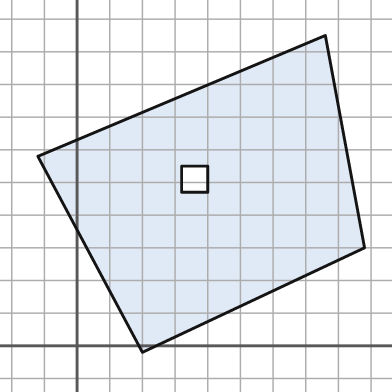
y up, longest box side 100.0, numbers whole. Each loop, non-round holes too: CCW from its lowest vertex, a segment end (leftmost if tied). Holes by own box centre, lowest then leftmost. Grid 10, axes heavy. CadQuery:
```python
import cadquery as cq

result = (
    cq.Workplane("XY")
    .moveTo(20.0, -2.0)
    .lineTo(88.0, 30.0)
    .lineTo(76.0, 95.0)
    .lineTo(-12.0, 58.0)
    .close()
    .moveTo(32.0, 47.0)
    .lineTo(40.0, 47.0)
    .lineTo(40.0, 55.0)
    .lineTo(32.0, 55.0)
    .close()
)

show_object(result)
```